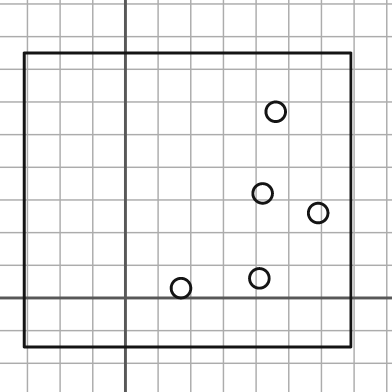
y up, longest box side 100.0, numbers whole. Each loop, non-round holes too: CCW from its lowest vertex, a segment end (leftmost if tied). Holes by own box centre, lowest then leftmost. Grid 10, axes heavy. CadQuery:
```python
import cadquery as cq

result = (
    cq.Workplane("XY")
    .moveTo(-31.0, -15.0)
    .lineTo(69.0, -15.0)
    .lineTo(69.0, 75.0)
    .lineTo(-31.0, 75.0)
    .close()
    .moveTo(17.0, 3.0)
    .circle(3.0)
    .moveTo(41.0, 6.0)
    .circle(3.0)
    .moveTo(59.0, 26.0)
    .circle(3.0)
    .moveTo(42.0, 32.0)
    .circle(3.0)
    .moveTo(46.0, 57.0)
    .circle(3.0)
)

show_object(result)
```